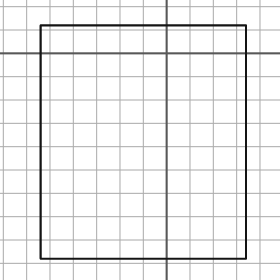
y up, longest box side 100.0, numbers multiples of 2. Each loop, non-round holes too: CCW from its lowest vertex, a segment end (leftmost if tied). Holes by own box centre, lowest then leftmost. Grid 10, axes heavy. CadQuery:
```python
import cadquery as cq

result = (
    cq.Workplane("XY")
    .moveTo(-54.0, -88.0)
    .lineTo(34.0, -88.0)
    .lineTo(34.0, 12.0)
    .lineTo(-54.0, 12.0)
    .close()
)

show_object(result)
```